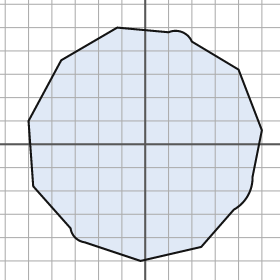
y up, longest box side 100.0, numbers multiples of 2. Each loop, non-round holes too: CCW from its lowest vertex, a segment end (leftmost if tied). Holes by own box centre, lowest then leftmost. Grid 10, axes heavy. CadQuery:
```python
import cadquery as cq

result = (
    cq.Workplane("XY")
    .moveTo(-2.0, -50.0)
    .lineTo(24.0, -44.0)
    .lineTo(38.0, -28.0)
    .threePointArc((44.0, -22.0), (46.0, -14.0))
    .lineTo(50.0, 6.0)
    .lineTo(40.0, 32.0)
    .lineTo(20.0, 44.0)
    .threePointArc((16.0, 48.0), (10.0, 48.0))
    .lineTo(-12.0, 50.0)
    .lineTo(-36.0, 36.0)
    .lineTo(-50.0, 10.0)
    .lineTo(-48.0, -18.0)
    .lineTo(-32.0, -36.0)
    .threePointArc((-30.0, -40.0), (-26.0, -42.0))
    .close()
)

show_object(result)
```